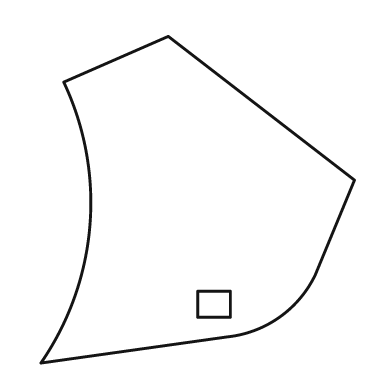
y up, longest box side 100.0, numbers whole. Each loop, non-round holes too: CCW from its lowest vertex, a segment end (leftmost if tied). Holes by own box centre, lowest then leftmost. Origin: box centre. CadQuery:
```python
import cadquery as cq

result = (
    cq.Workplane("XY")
    .moveTo(-48.0, -50.0)
    .lineTo(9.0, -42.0)
    .threePointArc((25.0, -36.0), (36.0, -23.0))
    .lineTo(48.0, 6.0)
    .lineTo(-9.0, 50.0)
    .lineTo(-41.0, 36.0)
    .threePointArc((-33.0, -8.0), (-48.0, -50.0))
    .close()
    .moveTo(0.0, -36.0)
    .lineTo(10.0, -36.0)
    .lineTo(10.0, -28.0)
    .lineTo(0.0, -28.0)
    .close()
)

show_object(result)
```